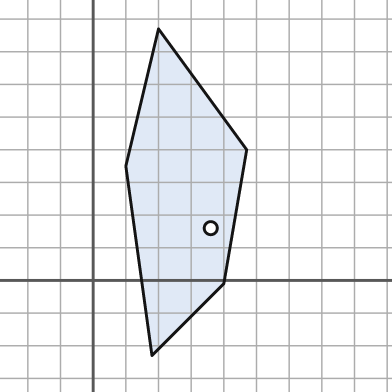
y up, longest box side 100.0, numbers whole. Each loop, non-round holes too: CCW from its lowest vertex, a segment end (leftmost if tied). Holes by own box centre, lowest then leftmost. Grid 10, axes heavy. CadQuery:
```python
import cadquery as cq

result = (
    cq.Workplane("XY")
    .moveTo(18.0, -23.0)
    .lineTo(40.0, -1.0)
    .lineTo(47.0, 40.0)
    .lineTo(20.0, 77.0)
    .lineTo(10.0, 35.0)
    .close()
    .moveTo(36.0, 16.0)
    .circle(2.0)
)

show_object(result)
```